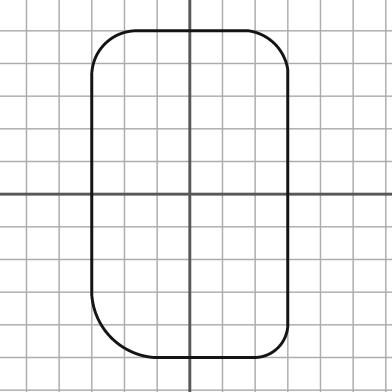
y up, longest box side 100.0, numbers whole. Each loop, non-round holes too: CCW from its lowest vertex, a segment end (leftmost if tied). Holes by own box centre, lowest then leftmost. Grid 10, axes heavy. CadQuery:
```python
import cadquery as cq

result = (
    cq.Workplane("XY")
    .moveTo(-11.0, -50.0)
    .lineTo(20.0, -50.0)
    .threePointArc((27.0, -47.0), (30.0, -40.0))
    .lineTo(30.0, 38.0)
    .threePointArc((26.0, 46.0), (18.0, 50.0))
    .lineTo(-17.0, 50.0)
    .threePointArc((-26.0, 46.0), (-30.0, 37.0))
    .lineTo(-30.0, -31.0)
    .threePointArc((-24.0, -44.0), (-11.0, -50.0))
    .close()
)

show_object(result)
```